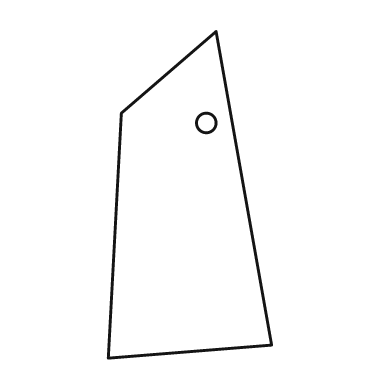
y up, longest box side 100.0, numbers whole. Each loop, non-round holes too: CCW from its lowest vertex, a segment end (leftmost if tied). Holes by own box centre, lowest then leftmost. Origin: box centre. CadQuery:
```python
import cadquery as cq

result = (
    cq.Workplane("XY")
    .moveTo(-25.0, -50.0)
    .lineTo(25.0, -46.0)
    .lineTo(8.0, 50.0)
    .lineTo(-21.0, 25.0)
    .close()
    .moveTo(5.0, 22.0)
    .circle(3.0)
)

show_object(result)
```